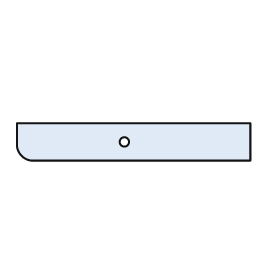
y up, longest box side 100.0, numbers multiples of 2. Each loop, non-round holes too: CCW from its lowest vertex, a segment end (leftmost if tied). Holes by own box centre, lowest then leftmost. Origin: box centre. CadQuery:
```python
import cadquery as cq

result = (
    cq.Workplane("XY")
    .moveTo(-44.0, -8.0)
    .lineTo(50.0, -8.0)
    .lineTo(50.0, 8.0)
    .lineTo(-50.0, 8.0)
    .lineTo(-50.0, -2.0)
    .threePointArc((-48.0, -6.0), (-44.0, -8.0))
    .close()
    .moveTo(-4.0, 0.0)
    .circle(2.0)
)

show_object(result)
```